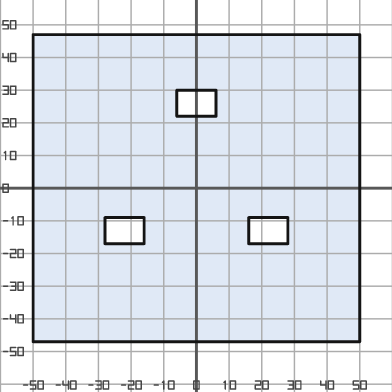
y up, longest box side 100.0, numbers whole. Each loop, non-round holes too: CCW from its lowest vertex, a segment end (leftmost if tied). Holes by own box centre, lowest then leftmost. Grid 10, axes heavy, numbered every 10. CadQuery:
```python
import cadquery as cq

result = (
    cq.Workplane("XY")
    .moveTo(-50.0, -47.0)
    .lineTo(50.0, -47.0)
    .lineTo(50.0, 47.0)
    .lineTo(-50.0, 47.0)
    .close()
    .moveTo(-28.0, -17.0)
    .lineTo(-16.0, -17.0)
    .lineTo(-16.0, -9.0)
    .lineTo(-28.0, -9.0)
    .close()
    .moveTo(16.0, -17.0)
    .lineTo(28.0, -17.0)
    .lineTo(28.0, -9.0)
    .lineTo(16.0, -9.0)
    .close()
    .moveTo(-6.0, 22.0)
    .lineTo(6.0, 22.0)
    .lineTo(6.0, 30.0)
    .lineTo(-6.0, 30.0)
    .close()
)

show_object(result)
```